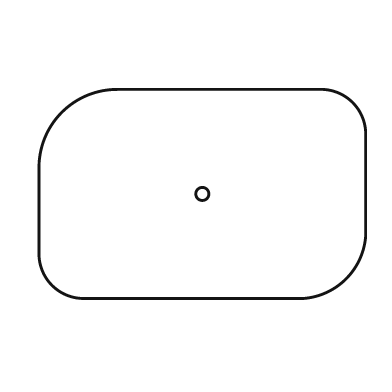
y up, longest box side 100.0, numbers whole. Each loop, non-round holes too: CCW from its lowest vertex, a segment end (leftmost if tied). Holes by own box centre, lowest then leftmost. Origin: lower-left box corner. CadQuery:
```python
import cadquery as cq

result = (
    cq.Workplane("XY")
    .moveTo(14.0, 0.0)
    .lineTo(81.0, 0.0)
    .threePointArc((94.0, 6.0), (100.0, 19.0))
    .lineTo(100.0, 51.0)
    .threePointArc((96.0, 60.0), (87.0, 64.0))
    .lineTo(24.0, 64.0)
    .threePointArc((7.0, 57.0), (0.0, 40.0))
    .lineTo(0.0, 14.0)
    .threePointArc((4.0, 4.0), (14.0, 0.0))
    .close()
    .moveTo(50.0, 32.0)
    .circle(2.0)
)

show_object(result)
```